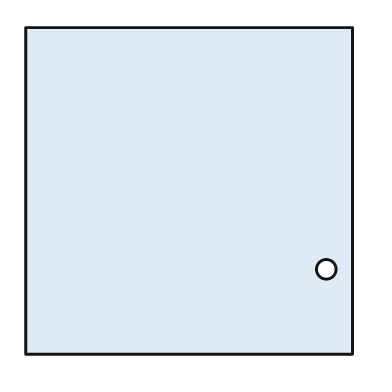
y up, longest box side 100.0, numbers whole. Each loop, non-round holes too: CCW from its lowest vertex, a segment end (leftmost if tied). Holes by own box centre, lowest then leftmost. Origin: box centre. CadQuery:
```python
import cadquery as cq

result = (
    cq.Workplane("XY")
    .moveTo(-50.0, -50.0)
    .lineTo(50.0, -50.0)
    .lineTo(50.0, 50.0)
    .lineTo(-50.0, 50.0)
    .close()
    .moveTo(42.0, -24.0)
    .circle(3.0)
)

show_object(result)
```